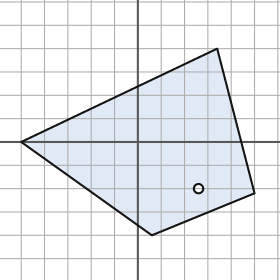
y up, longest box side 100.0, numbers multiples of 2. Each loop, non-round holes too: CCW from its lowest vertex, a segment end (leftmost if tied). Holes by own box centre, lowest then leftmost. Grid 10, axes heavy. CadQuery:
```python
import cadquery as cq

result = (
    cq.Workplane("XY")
    .moveTo(6.0, -40.0)
    .lineTo(50.0, -22.0)
    .lineTo(34.0, 40.0)
    .lineTo(-50.0, 0.0)
    .close()
    .moveTo(26.0, -20.0)
    .circle(2.0)
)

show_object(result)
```